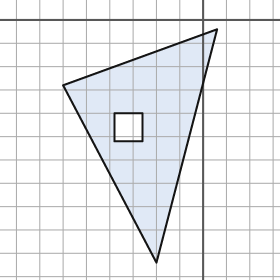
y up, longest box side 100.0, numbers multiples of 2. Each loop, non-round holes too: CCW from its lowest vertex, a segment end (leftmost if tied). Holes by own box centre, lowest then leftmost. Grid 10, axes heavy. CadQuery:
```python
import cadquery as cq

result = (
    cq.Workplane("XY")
    .moveTo(-20.0, -104.0)
    .lineTo(6.0, -4.0)
    .lineTo(-60.0, -28.0)
    .close()
    .moveTo(-38.0, -52.0)
    .lineTo(-26.0, -52.0)
    .lineTo(-26.0, -40.0)
    .lineTo(-38.0, -40.0)
    .close()
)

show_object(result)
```